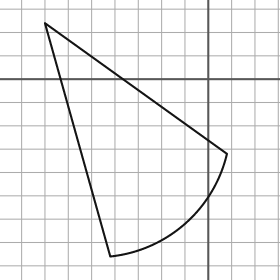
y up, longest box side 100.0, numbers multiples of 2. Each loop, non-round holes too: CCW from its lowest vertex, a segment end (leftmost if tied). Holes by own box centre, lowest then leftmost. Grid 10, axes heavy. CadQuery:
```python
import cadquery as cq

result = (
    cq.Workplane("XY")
    .moveTo(-42.0, -76.0)
    .threePointArc((-10.0, -62.0), (8.0, -32.0))
    .lineTo(-70.0, 24.0)
    .close()
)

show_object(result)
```